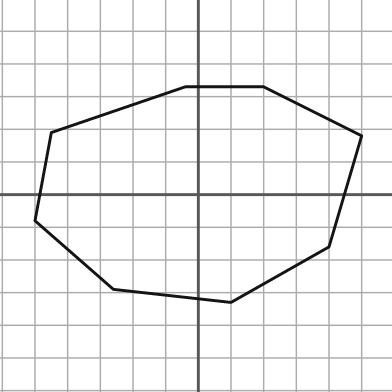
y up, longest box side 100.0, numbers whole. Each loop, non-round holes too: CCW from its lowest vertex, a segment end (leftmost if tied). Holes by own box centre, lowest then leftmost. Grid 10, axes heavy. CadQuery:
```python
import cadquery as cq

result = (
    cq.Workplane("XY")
    .moveTo(10.0, -33.0)
    .lineTo(40.0, -16.0)
    .lineTo(50.0, 18.0)
    .lineTo(20.0, 33.0)
    .lineTo(-4.0, 33.0)
    .lineTo(-45.0, 19.0)
    .lineTo(-50.0, -8.0)
    .lineTo(-26.0, -29.0)
    .close()
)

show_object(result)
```